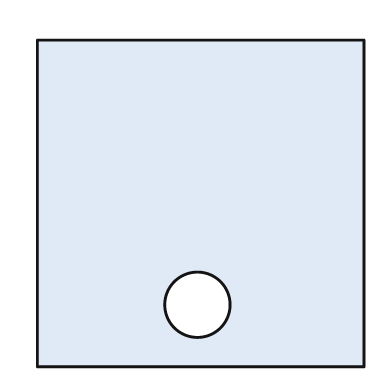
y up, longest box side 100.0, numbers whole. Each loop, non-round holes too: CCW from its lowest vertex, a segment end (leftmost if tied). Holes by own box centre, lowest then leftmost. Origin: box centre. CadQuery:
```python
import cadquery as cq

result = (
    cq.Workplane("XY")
    .moveTo(-50.0, -50.0)
    .lineTo(50.0, -50.0)
    .lineTo(50.0, 50.0)
    .lineTo(-50.0, 50.0)
    .close()
    .moveTo(-1.0, -31.0)
    .circle(10.0)
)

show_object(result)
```